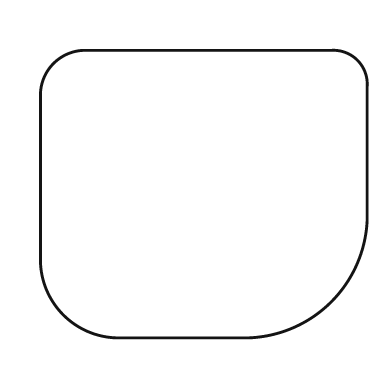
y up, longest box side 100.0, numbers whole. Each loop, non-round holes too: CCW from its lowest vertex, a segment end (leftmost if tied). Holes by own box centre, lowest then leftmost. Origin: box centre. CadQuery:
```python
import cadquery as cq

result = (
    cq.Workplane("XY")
    .moveTo(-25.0, -44.0)
    .lineTo(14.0, -44.0)
    .threePointArc((39.0, -33.0), (50.0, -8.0))
    .lineTo(50.0, 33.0)
    .threePointArc((47.0, 41.0), (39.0, 44.0))
    .lineTo(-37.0, 44.0)
    .threePointArc((-46.0, 40.0), (-50.0, 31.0))
    .lineTo(-50.0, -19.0)
    .threePointArc((-43.0, -37.0), (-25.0, -44.0))
    .close()
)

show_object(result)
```